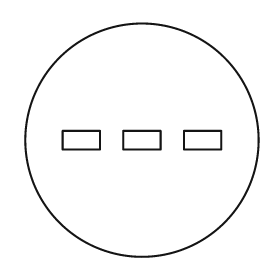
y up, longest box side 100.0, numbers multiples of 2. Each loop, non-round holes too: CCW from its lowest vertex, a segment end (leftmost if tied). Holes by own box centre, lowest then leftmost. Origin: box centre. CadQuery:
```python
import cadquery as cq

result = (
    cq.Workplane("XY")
    .moveTo(0.0, 0.0)
    .circle(50.0)
    .moveTo(-34.0, -4.0)
    .lineTo(-18.0, -4.0)
    .lineTo(-18.0, 4.0)
    .lineTo(-34.0, 4.0)
    .close()
    .moveTo(-8.0, -4.0)
    .lineTo(8.0, -4.0)
    .lineTo(8.0, 4.0)
    .lineTo(-8.0, 4.0)
    .close()
    .moveTo(18.0, -4.0)
    .lineTo(34.0, -4.0)
    .lineTo(34.0, 4.0)
    .lineTo(18.0, 4.0)
    .close()
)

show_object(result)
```